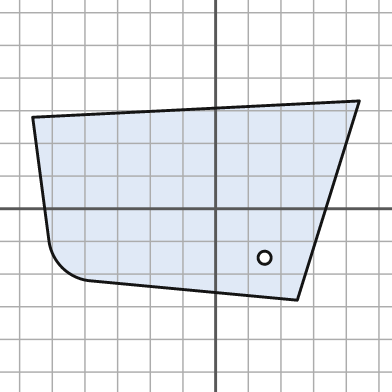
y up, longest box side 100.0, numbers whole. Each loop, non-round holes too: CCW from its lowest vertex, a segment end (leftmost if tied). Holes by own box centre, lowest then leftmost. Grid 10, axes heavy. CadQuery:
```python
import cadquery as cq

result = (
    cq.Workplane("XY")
    .moveTo(25.0, -28.0)
    .lineTo(44.0, 33.0)
    .lineTo(-56.0, 28.0)
    .lineTo(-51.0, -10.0)
    .threePointArc((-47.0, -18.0), (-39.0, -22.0))
    .close()
    .moveTo(15.0, -15.0)
    .circle(2.0)
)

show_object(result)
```